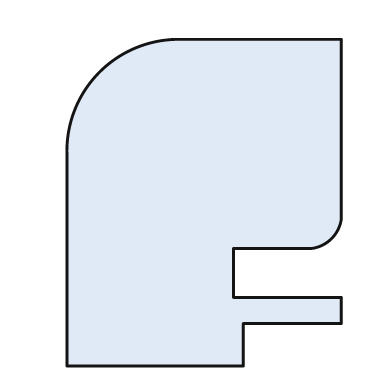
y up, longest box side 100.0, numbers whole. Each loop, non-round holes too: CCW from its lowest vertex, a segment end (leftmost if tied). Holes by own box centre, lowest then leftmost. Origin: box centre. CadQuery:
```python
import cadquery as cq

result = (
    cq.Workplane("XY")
    .moveTo(-42.0, -50.0)
    .lineTo(12.0, -50.0)
    .lineTo(12.0, -37.0)
    .lineTo(42.0, -37.0)
    .lineTo(42.0, -29.0)
    .lineTo(9.0, -29.0)
    .lineTo(9.0, -14.0)
    .lineTo(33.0, -14.0)
    .threePointArc((39.0, -11.0), (42.0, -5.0))
    .lineTo(42.0, 50.0)
    .lineTo(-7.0, 50.0)
    .threePointArc((-32.0, 40.0), (-42.0, 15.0))
    .close()
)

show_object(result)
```